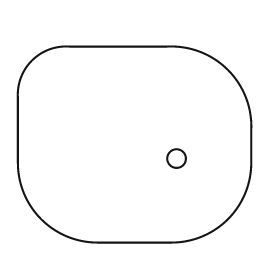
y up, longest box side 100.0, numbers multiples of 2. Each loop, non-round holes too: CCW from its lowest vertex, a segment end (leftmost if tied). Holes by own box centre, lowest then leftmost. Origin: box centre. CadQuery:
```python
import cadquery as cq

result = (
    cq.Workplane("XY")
    .moveTo(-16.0, -42.0)
    .lineTo(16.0, -42.0)
    .threePointArc((40.0, -32.0), (50.0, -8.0))
    .lineTo(50.0, 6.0)
    .threePointArc((40.0, 32.0), (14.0, 42.0))
    .lineTo(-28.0, 42.0)
    .threePointArc((-44.0, 36.0), (-50.0, 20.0))
    .lineTo(-50.0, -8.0)
    .threePointArc((-40.0, -32.0), (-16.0, -42.0))
    .close()
    .moveTo(18.0, -6.0)
    .circle(4.0)
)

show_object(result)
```